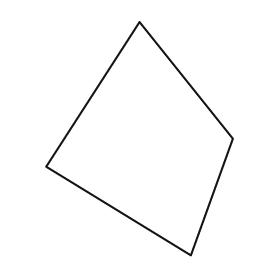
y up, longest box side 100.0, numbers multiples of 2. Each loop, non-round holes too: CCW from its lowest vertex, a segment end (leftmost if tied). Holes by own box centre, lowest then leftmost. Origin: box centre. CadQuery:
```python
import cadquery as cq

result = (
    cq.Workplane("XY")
    .moveTo(22.0, -50.0)
    .lineTo(40.0, 0.0)
    .lineTo(0.0, 50.0)
    .lineTo(-40.0, -12.0)
    .close()
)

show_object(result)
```